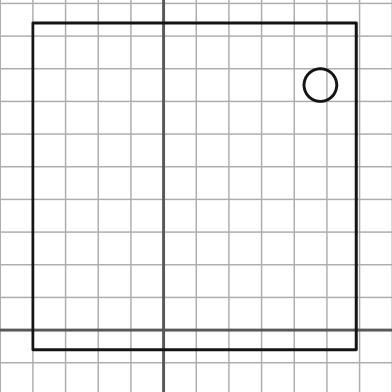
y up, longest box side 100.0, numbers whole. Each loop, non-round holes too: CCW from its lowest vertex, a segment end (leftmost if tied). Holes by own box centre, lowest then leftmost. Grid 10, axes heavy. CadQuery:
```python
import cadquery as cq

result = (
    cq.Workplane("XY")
    .moveTo(-40.0, -6.0)
    .lineTo(59.0, -6.0)
    .lineTo(59.0, 94.0)
    .lineTo(-40.0, 94.0)
    .close()
    .moveTo(48.0, 75.0)
    .circle(5.0)
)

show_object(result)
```